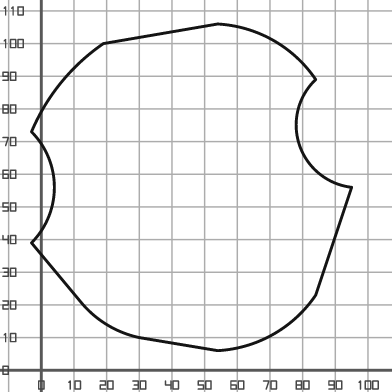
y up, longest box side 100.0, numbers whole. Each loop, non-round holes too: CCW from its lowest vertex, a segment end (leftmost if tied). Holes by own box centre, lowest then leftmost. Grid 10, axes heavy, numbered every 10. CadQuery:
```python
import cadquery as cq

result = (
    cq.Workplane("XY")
    .moveTo(54.0, 6.0)
    .threePointArc((71.0, 11.0), (84.0, 23.0))
    .lineTo(95.0, 56.0)
    .threePointArc((79.0, 69.0), (84.0, 89.0))
    .threePointArc((71.0, 101.0), (54.0, 106.0))
    .lineTo(19.0, 100.0)
    .threePointArc((6.0, 88.0), (-3.0, 73.0))
    .threePointArc((4.0, 56.0), (-3.0, 39.0))
    .lineTo(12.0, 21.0)
    .threePointArc((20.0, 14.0), (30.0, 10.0))
    .close()
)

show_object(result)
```